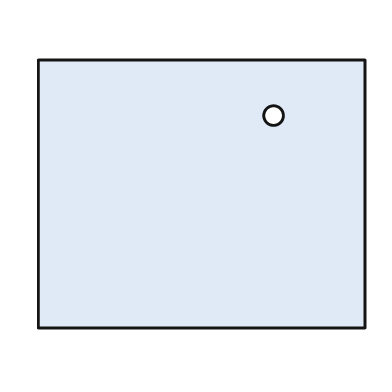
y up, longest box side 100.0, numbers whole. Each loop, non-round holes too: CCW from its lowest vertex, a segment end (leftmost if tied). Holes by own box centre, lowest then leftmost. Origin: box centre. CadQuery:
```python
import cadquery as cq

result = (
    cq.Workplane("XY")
    .moveTo(-50.0, -41.0)
    .lineTo(50.0, -41.0)
    .lineTo(50.0, 41.0)
    .lineTo(-50.0, 41.0)
    .close()
    .moveTo(22.0, 24.0)
    .circle(3.0)
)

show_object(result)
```